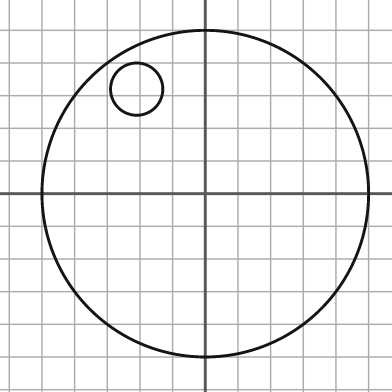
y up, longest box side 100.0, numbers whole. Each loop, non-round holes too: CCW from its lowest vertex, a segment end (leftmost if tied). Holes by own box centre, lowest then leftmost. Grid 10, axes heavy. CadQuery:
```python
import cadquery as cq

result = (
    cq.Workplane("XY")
    .moveTo(0.0, 0.0)
    .circle(50.0)
    .moveTo(-21.0, 32.0)
    .circle(8.0)
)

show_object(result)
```